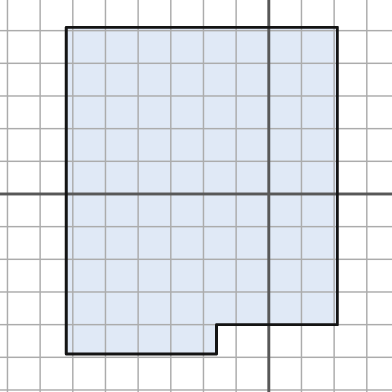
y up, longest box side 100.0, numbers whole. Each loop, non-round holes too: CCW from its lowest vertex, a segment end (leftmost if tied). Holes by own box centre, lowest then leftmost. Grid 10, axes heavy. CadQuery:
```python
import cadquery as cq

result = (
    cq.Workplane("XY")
    .moveTo(-62.0, -49.0)
    .lineTo(-16.0, -49.0)
    .lineTo(-16.0, -40.0)
    .lineTo(21.0, -40.0)
    .lineTo(21.0, 51.0)
    .lineTo(-62.0, 51.0)
    .close()
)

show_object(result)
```